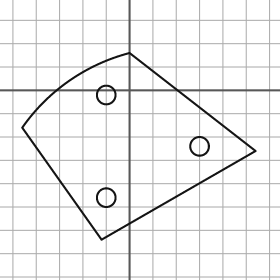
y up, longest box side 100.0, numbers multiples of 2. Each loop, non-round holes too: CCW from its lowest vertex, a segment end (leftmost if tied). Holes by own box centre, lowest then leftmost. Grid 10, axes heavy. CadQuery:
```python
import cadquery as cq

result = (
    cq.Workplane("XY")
    .moveTo(-12.0, -64.0)
    .lineTo(54.0, -26.0)
    .lineTo(0.0, 16.0)
    .threePointArc((-26.0, 4.0), (-46.0, -16.0))
    .close()
    .moveTo(-10.0, -46.0)
    .circle(4.0)
    .moveTo(30.0, -24.0)
    .circle(4.0)
    .moveTo(-10.0, -2.0)
    .circle(4.0)
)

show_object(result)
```